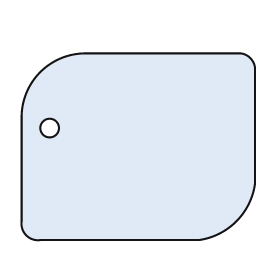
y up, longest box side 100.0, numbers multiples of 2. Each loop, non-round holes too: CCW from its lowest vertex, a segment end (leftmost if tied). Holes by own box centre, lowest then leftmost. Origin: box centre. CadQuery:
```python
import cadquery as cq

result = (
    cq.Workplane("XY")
    .moveTo(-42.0, -40.0)
    .lineTo(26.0, -40.0)
    .threePointArc((42.0, -32.0), (50.0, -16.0))
    .lineTo(50.0, 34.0)
    .threePointArc((48.0, 38.0), (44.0, 40.0))
    .lineTo(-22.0, 40.0)
    .threePointArc((-42.0, 32.0), (-50.0, 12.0))
    .lineTo(-50.0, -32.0)
    .threePointArc((-48.0, -38.0), (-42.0, -40.0))
    .close()
    .moveTo(-38.0, 8.0)
    .circle(4.0)
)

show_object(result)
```